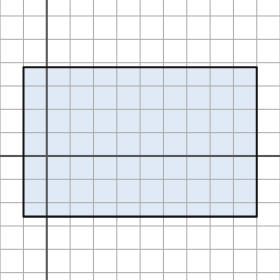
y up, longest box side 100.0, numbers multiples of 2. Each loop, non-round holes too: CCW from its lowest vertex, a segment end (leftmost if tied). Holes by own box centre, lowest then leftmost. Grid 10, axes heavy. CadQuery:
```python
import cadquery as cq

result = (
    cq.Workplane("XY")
    .moveTo(-10.0, -26.0)
    .lineTo(90.0, -26.0)
    .lineTo(90.0, 38.0)
    .lineTo(-10.0, 38.0)
    .close()
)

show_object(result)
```